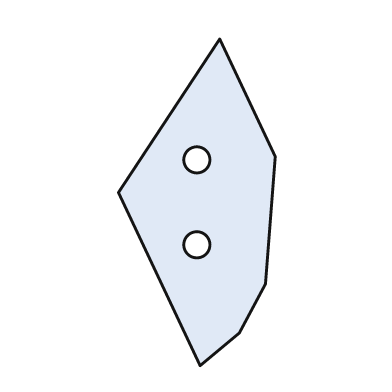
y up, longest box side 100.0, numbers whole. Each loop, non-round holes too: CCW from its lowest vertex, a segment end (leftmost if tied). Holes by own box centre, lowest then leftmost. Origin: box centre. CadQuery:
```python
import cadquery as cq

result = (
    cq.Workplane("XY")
    .moveTo(1.0, -50.0)
    .lineTo(13.0, -40.0)
    .lineTo(21.0, -25.0)
    .lineTo(24.0, 14.0)
    .lineTo(7.0, 50.0)
    .lineTo(-24.0, 3.0)
    .close()
    .moveTo(0.0, -13.0)
    .circle(4.0)
    .moveTo(0.0, 13.0)
    .circle(4.0)
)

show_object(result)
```